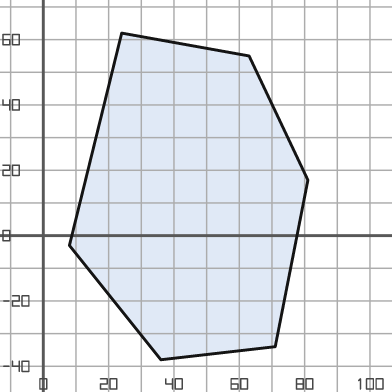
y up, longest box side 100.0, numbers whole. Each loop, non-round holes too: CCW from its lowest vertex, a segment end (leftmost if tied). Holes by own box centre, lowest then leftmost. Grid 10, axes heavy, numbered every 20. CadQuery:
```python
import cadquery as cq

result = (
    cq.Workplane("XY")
    .moveTo(36.0, -38.0)
    .lineTo(71.0, -34.0)
    .lineTo(81.0, 17.0)
    .lineTo(63.0, 55.0)
    .lineTo(24.0, 62.0)
    .lineTo(8.0, -3.0)
    .close()
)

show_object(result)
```